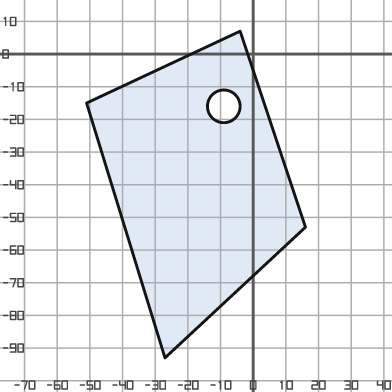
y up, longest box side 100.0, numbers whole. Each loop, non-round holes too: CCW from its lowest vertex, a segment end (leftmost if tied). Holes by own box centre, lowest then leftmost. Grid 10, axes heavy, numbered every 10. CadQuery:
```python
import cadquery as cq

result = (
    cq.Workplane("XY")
    .moveTo(-27.0, -93.0)
    .lineTo(16.0, -53.0)
    .lineTo(-4.0, 7.0)
    .lineTo(-51.0, -15.0)
    .close()
    .moveTo(-9.0, -16.0)
    .circle(5.0)
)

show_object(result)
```